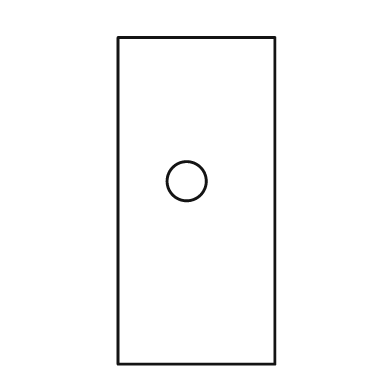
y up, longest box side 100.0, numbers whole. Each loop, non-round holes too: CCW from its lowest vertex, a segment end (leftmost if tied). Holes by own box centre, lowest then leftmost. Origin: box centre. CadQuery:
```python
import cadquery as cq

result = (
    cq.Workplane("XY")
    .moveTo(-24.0, -50.0)
    .lineTo(24.0, -50.0)
    .lineTo(24.0, 50.0)
    .lineTo(-24.0, 50.0)
    .close()
    .moveTo(-3.0, 6.0)
    .circle(6.0)
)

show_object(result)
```